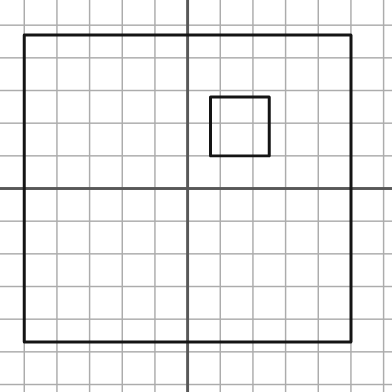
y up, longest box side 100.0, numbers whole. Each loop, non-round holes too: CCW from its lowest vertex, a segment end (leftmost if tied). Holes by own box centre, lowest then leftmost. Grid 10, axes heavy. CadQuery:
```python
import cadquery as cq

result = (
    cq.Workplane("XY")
    .moveTo(-50.0, -47.0)
    .lineTo(50.0, -47.0)
    .lineTo(50.0, 47.0)
    .lineTo(-50.0, 47.0)
    .close()
    .moveTo(7.0, 10.0)
    .lineTo(25.0, 10.0)
    .lineTo(25.0, 28.0)
    .lineTo(7.0, 28.0)
    .close()
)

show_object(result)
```